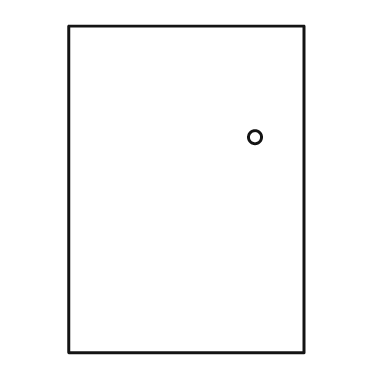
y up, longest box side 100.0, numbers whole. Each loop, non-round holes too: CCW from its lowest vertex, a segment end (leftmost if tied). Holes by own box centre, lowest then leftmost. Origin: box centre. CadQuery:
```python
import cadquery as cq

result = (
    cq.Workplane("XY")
    .moveTo(-36.0, -50.0)
    .lineTo(36.0, -50.0)
    .lineTo(36.0, 50.0)
    .lineTo(-36.0, 50.0)
    .close()
    .moveTo(21.0, 16.0)
    .circle(2.0)
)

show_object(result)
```